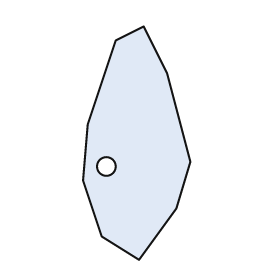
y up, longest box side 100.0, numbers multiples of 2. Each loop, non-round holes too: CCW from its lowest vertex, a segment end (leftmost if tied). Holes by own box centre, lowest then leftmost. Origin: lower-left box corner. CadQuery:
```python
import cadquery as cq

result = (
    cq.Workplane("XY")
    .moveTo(24.0, 0.0)
    .lineTo(40.0, 22.0)
    .lineTo(46.0, 42.0)
    .lineTo(36.0, 80.0)
    .lineTo(26.0, 100.0)
    .lineTo(14.0, 94.0)
    .lineTo(2.0, 58.0)
    .lineTo(0.0, 34.0)
    .lineTo(8.0, 10.0)
    .close()
    .moveTo(10.0, 40.0)
    .circle(4.0)
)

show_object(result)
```